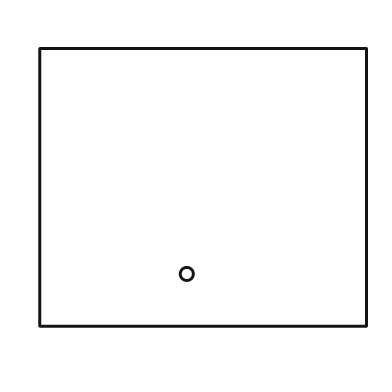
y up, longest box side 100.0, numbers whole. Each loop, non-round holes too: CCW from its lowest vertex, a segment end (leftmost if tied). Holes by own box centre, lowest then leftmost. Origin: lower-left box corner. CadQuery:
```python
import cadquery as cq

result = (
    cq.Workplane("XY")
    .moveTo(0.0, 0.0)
    .lineTo(100.0, 0.0)
    .lineTo(100.0, 85.0)
    .lineTo(0.0, 85.0)
    .close()
    .moveTo(45.0, 16.0)
    .circle(2.0)
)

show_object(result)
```